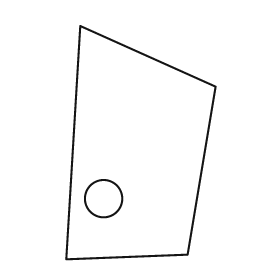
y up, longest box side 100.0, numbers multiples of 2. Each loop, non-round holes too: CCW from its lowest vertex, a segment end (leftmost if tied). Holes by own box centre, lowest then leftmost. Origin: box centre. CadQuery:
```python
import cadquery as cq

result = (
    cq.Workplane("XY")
    .moveTo(-32.0, -50.0)
    .lineTo(20.0, -48.0)
    .lineTo(32.0, 24.0)
    .lineTo(-26.0, 50.0)
    .close()
    .moveTo(-16.0, -24.0)
    .circle(8.0)
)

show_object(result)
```